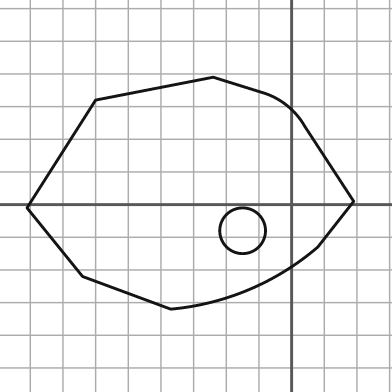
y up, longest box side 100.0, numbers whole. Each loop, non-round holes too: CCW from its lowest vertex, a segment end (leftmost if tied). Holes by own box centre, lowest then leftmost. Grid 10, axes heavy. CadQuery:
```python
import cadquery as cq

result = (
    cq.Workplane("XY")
    .moveTo(-37.0, -32.0)
    .threePointArc((-13.0, -26.0), (8.0, -13.0))
    .lineTo(19.0, 1.0)
    .lineTo(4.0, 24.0)
    .threePointArc((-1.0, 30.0), (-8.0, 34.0))
    .lineTo(-24.0, 39.0)
    .lineTo(-60.0, 32.0)
    .lineTo(-81.0, -1.0)
    .lineTo(-64.0, -22.0)
    .close()
    .moveTo(-15.0, -8.0)
    .circle(7.0)
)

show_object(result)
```